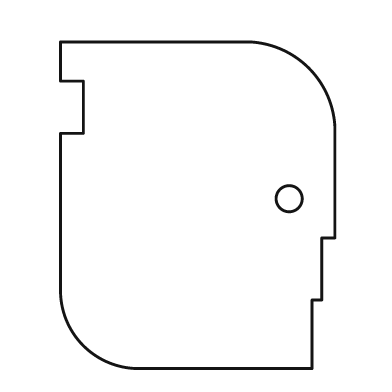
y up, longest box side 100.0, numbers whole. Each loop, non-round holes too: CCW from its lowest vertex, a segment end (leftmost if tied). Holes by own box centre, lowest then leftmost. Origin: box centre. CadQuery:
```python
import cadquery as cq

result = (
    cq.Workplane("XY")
    .moveTo(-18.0, -50.0)
    .lineTo(35.0, -50.0)
    .lineTo(35.0, -29.0)
    .lineTo(38.0, -29.0)
    .lineTo(38.0, -10.0)
    .lineTo(42.0, -10.0)
    .lineTo(42.0, 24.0)
    .threePointArc((34.0, 42.0), (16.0, 50.0))
    .lineTo(-42.0, 50.0)
    .lineTo(-42.0, 38.0)
    .lineTo(-35.0, 38.0)
    .lineTo(-35.0, 22.0)
    .lineTo(-42.0, 22.0)
    .lineTo(-42.0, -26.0)
    .threePointArc((-35.0, -43.0), (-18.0, -50.0))
    .close()
    .moveTo(28.0, 2.0)
    .circle(4.0)
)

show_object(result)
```